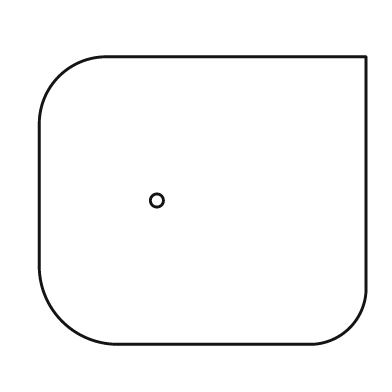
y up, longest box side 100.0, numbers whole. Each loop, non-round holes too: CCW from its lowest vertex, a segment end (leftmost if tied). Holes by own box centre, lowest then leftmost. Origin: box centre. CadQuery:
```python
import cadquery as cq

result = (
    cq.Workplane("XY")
    .moveTo(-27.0, -44.0)
    .lineTo(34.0, -44.0)
    .threePointArc((45.0, -39.0), (50.0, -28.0))
    .lineTo(50.0, 44.0)
    .lineTo(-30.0, 44.0)
    .threePointArc((-44.0, 38.0), (-50.0, 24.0))
    .lineTo(-50.0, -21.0)
    .threePointArc((-43.0, -37.0), (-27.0, -44.0))
    .close()
    .moveTo(-14.0, 0.0)
    .circle(2.0)
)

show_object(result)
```